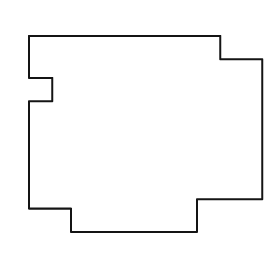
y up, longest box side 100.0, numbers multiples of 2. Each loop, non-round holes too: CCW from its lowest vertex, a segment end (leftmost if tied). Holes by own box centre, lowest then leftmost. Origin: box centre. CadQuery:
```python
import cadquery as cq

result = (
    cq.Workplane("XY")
    .moveTo(-32.0, -42.0)
    .lineTo(22.0, -42.0)
    .lineTo(22.0, -28.0)
    .lineTo(50.0, -28.0)
    .lineTo(50.0, 32.0)
    .lineTo(32.0, 32.0)
    .lineTo(32.0, 42.0)
    .lineTo(-50.0, 42.0)
    .lineTo(-50.0, 24.0)
    .lineTo(-40.0, 24.0)
    .lineTo(-40.0, 14.0)
    .lineTo(-50.0, 14.0)
    .lineTo(-50.0, -32.0)
    .lineTo(-32.0, -32.0)
    .close()
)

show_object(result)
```